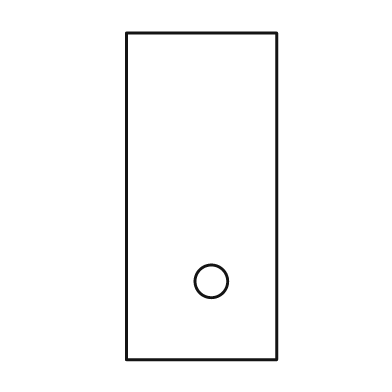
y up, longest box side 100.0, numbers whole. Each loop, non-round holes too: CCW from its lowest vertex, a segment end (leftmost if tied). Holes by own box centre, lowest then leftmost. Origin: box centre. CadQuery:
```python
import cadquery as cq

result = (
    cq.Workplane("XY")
    .moveTo(-23.0, -50.0)
    .lineTo(23.0, -50.0)
    .lineTo(23.0, 50.0)
    .lineTo(-23.0, 50.0)
    .close()
    .moveTo(3.0, -26.0)
    .circle(5.0)
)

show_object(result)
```